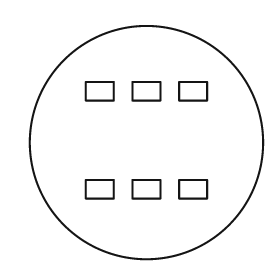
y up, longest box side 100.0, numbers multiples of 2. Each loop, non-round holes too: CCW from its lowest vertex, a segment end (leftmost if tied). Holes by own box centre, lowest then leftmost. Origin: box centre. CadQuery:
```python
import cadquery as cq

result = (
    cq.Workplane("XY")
    .moveTo(0.0, 0.0)
    .circle(50.0)
    .moveTo(-26.0, -24.0)
    .lineTo(-14.0, -24.0)
    .lineTo(-14.0, -16.0)
    .lineTo(-26.0, -16.0)
    .close()
    .moveTo(-6.0, -24.0)
    .lineTo(6.0, -24.0)
    .lineTo(6.0, -16.0)
    .lineTo(-6.0, -16.0)
    .close()
    .moveTo(14.0, -24.0)
    .lineTo(26.0, -24.0)
    .lineTo(26.0, -16.0)
    .lineTo(14.0, -16.0)
    .close()
    .moveTo(-26.0, 18.0)
    .lineTo(-14.0, 18.0)
    .lineTo(-14.0, 26.0)
    .lineTo(-26.0, 26.0)
    .close()
    .moveTo(-6.0, 18.0)
    .lineTo(6.0, 18.0)
    .lineTo(6.0, 26.0)
    .lineTo(-6.0, 26.0)
    .close()
    .moveTo(14.0, 18.0)
    .lineTo(26.0, 18.0)
    .lineTo(26.0, 26.0)
    .lineTo(14.0, 26.0)
    .close()
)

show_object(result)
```